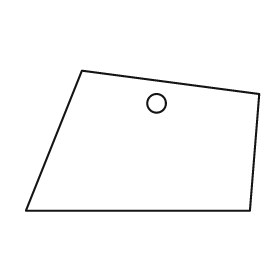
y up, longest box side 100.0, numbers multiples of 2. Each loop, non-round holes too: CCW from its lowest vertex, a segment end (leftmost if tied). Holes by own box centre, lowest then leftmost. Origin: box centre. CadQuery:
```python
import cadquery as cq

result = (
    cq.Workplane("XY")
    .moveTo(-50.0, -30.0)
    .lineTo(46.0, -30.0)
    .lineTo(50.0, 20.0)
    .lineTo(-26.0, 30.0)
    .close()
    .moveTo(6.0, 16.0)
    .circle(4.0)
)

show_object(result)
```